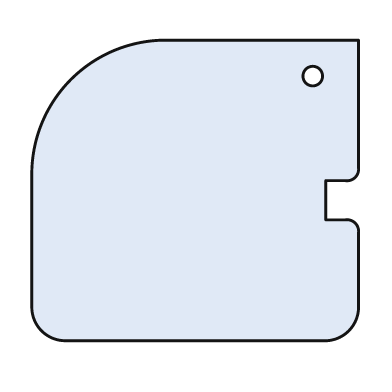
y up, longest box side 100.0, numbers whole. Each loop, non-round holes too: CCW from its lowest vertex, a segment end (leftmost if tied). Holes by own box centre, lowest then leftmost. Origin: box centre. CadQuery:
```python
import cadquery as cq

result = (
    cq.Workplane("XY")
    .moveTo(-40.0, -46.0)
    .lineTo(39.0, -46.0)
    .threePointArc((47.0, -43.0), (50.0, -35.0))
    .lineTo(50.0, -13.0)
    .threePointArc((49.0, -10.0), (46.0, -9.0))
    .lineTo(40.0, -9.0)
    .lineTo(40.0, 3.0)
    .lineTo(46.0, 3.0)
    .threePointArc((49.0, 4.0), (50.0, 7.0))
    .lineTo(50.0, 46.0)
    .lineTo(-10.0, 46.0)
    .threePointArc((-38.0, 34.0), (-50.0, 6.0))
    .lineTo(-50.0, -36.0)
    .threePointArc((-47.0, -43.0), (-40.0, -46.0))
    .close()
    .moveTo(36.0, 35.0)
    .circle(3.0)
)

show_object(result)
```